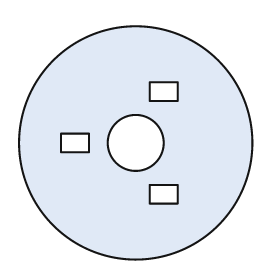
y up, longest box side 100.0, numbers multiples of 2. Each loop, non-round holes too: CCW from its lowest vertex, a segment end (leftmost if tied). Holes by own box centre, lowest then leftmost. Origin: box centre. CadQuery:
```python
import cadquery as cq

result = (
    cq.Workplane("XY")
    .moveTo(0.0, 0.0)
    .circle(50.0)
    .moveTo(6.0, -26.0)
    .lineTo(18.0, -26.0)
    .lineTo(18.0, -18.0)
    .lineTo(6.0, -18.0)
    .close()
    .moveTo(-32.0, -4.0)
    .lineTo(-20.0, -4.0)
    .lineTo(-20.0, 4.0)
    .lineTo(-32.0, 4.0)
    .close()
    .moveTo(0.0, 0.0)
    .circle(12.0)
    .moveTo(6.0, 18.0)
    .lineTo(18.0, 18.0)
    .lineTo(18.0, 26.0)
    .lineTo(6.0, 26.0)
    .close()
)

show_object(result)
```